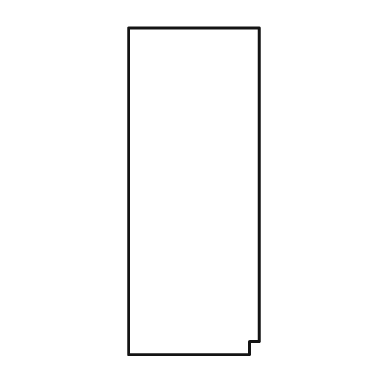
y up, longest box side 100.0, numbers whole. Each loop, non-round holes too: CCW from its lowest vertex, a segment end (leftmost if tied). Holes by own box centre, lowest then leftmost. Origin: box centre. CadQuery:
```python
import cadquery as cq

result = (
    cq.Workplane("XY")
    .moveTo(-20.0, -50.0)
    .lineTo(17.0, -50.0)
    .lineTo(17.0, -46.0)
    .lineTo(20.0, -46.0)
    .lineTo(20.0, 50.0)
    .lineTo(-20.0, 50.0)
    .close()
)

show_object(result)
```